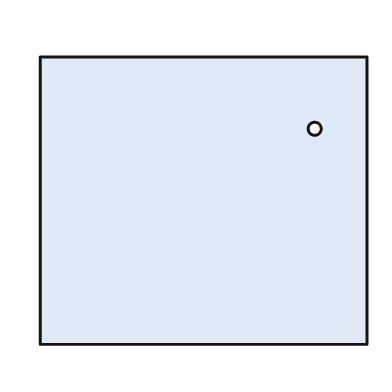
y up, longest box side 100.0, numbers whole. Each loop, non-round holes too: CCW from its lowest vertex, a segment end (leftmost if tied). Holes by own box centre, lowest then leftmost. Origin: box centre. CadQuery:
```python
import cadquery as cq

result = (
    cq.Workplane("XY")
    .moveTo(-50.0, -44.0)
    .lineTo(50.0, -44.0)
    .lineTo(50.0, 44.0)
    .lineTo(-50.0, 44.0)
    .close()
    .moveTo(34.0, 22.0)
    .circle(2.0)
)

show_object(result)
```